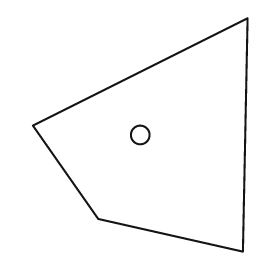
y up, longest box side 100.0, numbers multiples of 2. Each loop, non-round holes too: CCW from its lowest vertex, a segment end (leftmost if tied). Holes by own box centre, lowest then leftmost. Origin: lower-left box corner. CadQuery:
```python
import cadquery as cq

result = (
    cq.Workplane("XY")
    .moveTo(90.0, 0.0)
    .lineTo(92.0, 100.0)
    .lineTo(0.0, 54.0)
    .lineTo(28.0, 14.0)
    .close()
    .moveTo(46.0, 50.0)
    .circle(4.0)
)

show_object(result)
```